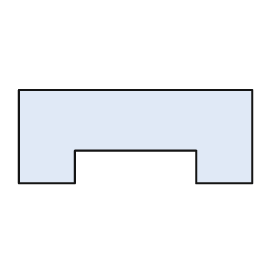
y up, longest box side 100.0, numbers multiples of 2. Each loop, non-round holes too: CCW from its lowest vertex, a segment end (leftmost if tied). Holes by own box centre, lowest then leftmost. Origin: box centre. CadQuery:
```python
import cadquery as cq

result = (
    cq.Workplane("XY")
    .moveTo(-50.0, -20.0)
    .lineTo(-26.0, -20.0)
    .lineTo(-26.0, -6.0)
    .lineTo(26.0, -6.0)
    .lineTo(26.0, -20.0)
    .lineTo(50.0, -20.0)
    .lineTo(50.0, 20.0)
    .lineTo(-50.0, 20.0)
    .close()
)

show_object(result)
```